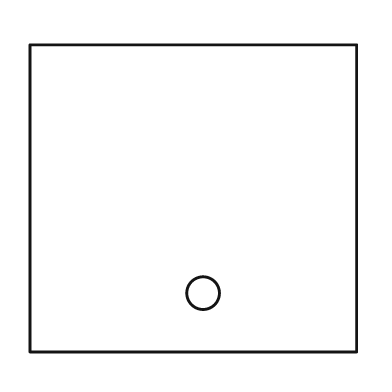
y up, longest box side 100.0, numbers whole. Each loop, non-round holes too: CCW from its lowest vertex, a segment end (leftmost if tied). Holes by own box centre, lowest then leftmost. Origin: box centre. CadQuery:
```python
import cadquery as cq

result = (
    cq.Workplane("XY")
    .moveTo(-50.0, -47.0)
    .lineTo(50.0, -47.0)
    .lineTo(50.0, 47.0)
    .lineTo(-50.0, 47.0)
    .close()
    .moveTo(3.0, -29.0)
    .circle(5.0)
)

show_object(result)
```